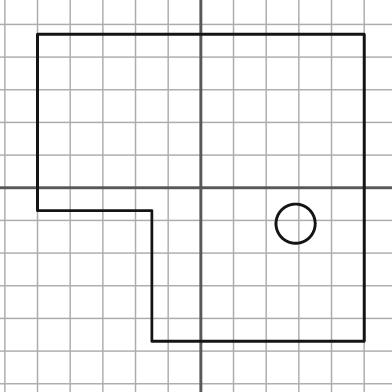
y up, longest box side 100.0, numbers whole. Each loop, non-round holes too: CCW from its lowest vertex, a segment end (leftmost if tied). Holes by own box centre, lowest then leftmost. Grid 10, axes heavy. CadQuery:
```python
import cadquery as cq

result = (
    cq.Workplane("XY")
    .moveTo(-15.0, -47.0)
    .lineTo(50.0, -47.0)
    .lineTo(50.0, 47.0)
    .lineTo(-50.0, 47.0)
    .lineTo(-50.0, -7.0)
    .lineTo(-15.0, -7.0)
    .close()
    .moveTo(29.0, -11.0)
    .circle(6.0)
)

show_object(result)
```